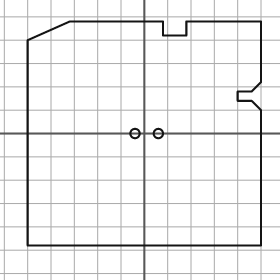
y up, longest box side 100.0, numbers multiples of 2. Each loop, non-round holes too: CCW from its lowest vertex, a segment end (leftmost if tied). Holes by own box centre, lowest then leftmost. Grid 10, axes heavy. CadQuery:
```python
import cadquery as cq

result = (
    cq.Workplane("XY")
    .moveTo(-50.0, -48.0)
    .lineTo(50.0, -48.0)
    .lineTo(50.0, 10.0)
    .lineTo(46.0, 14.0)
    .lineTo(40.0, 14.0)
    .lineTo(40.0, 18.0)
    .lineTo(46.0, 18.0)
    .lineTo(50.0, 22.0)
    .lineTo(50.0, 48.0)
    .lineTo(18.0, 48.0)
    .lineTo(18.0, 42.0)
    .lineTo(8.0, 42.0)
    .lineTo(8.0, 48.0)
    .lineTo(-32.0, 48.0)
    .lineTo(-50.0, 40.0)
    .close()
    .moveTo(-4.0, 0.0)
    .circle(2.0)
    .moveTo(6.0, 0.0)
    .circle(2.0)
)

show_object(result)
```